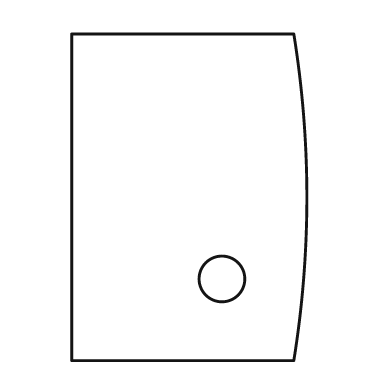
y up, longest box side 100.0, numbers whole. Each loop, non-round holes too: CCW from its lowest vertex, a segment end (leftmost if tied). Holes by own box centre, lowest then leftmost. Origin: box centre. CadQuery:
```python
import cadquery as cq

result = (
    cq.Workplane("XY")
    .moveTo(-36.0, -50.0)
    .lineTo(32.0, -50.0)
    .threePointArc((36.0, 0.0), (32.0, 50.0))
    .lineTo(-36.0, 50.0)
    .close()
    .moveTo(10.0, -25.0)
    .circle(7.0)
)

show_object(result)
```